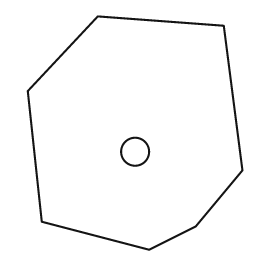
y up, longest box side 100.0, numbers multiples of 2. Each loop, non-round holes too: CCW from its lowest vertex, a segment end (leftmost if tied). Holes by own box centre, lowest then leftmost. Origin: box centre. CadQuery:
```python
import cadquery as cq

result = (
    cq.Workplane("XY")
    .moveTo(6.0, -50.0)
    .lineTo(26.0, -40.0)
    .lineTo(46.0, -16.0)
    .lineTo(38.0, 46.0)
    .lineTo(-16.0, 50.0)
    .lineTo(-46.0, 18.0)
    .lineTo(-40.0, -38.0)
    .close()
    .moveTo(0.0, -8.0)
    .circle(6.0)
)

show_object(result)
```